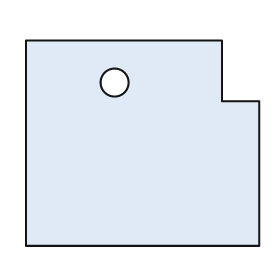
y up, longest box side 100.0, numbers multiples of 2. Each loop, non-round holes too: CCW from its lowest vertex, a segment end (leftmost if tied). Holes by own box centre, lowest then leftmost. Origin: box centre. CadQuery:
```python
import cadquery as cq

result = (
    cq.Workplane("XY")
    .moveTo(-50.0, -44.0)
    .lineTo(50.0, -44.0)
    .lineTo(50.0, 18.0)
    .lineTo(34.0, 18.0)
    .lineTo(34.0, 44.0)
    .lineTo(-50.0, 44.0)
    .close()
    .moveTo(-12.0, 26.0)
    .circle(6.0)
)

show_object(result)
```